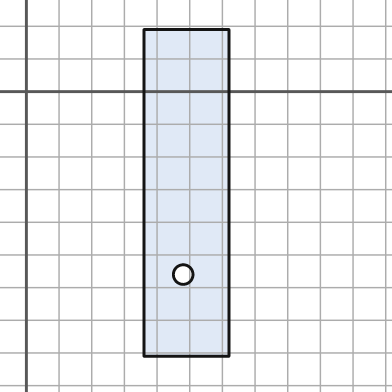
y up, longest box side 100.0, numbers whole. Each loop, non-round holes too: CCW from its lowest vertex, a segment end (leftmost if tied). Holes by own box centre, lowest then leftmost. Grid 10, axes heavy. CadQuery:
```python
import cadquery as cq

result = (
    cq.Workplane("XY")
    .moveTo(36.0, -81.0)
    .lineTo(62.0, -81.0)
    .lineTo(62.0, 19.0)
    .lineTo(36.0, 19.0)
    .close()
    .moveTo(48.0, -56.0)
    .circle(3.0)
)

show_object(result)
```